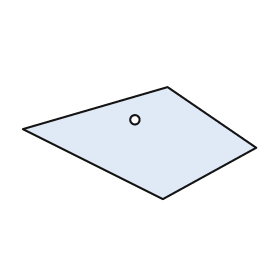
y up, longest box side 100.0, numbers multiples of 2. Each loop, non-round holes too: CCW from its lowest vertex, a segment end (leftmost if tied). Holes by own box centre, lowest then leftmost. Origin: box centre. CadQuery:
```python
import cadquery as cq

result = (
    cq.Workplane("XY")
    .moveTo(10.0, -24.0)
    .lineTo(50.0, -2.0)
    .lineTo(12.0, 24.0)
    .lineTo(-50.0, 6.0)
    .close()
    .moveTo(-2.0, 10.0)
    .circle(2.0)
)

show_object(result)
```